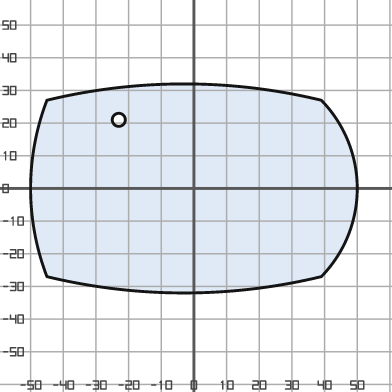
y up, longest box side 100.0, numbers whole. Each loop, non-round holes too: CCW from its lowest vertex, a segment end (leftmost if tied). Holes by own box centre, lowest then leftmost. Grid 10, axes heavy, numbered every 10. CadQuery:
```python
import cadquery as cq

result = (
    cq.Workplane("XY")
    .moveTo(-45.0, -27.0)
    .threePointArc((-3.0, -32.0), (39.0, -27.0))
    .threePointArc((50.0, 0.0), (39.0, 27.0))
    .threePointArc((-3.0, 32.0), (-45.0, 27.0))
    .threePointArc((-50.0, 0.0), (-45.0, -27.0))
    .close()
    .moveTo(-23.0, 21.0)
    .circle(2.0)
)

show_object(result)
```